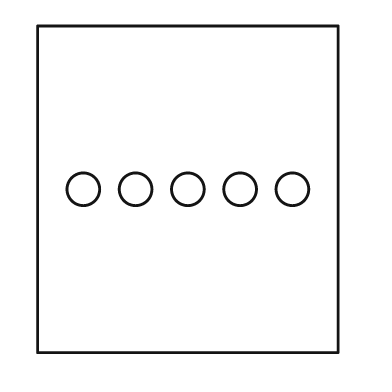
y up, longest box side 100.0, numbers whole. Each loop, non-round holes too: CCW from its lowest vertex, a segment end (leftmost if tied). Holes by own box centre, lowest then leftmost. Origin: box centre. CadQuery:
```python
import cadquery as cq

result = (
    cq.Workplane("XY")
    .moveTo(-46.0, -50.0)
    .lineTo(46.0, -50.0)
    .lineTo(46.0, 50.0)
    .lineTo(-46.0, 50.0)
    .close()
    .moveTo(-32.0, 0.0)
    .circle(5.0)
    .moveTo(-16.0, 0.0)
    .circle(5.0)
    .moveTo(0.0, 0.0)
    .circle(5.0)
    .moveTo(16.0, 0.0)
    .circle(5.0)
    .moveTo(32.0, 0.0)
    .circle(5.0)
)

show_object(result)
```